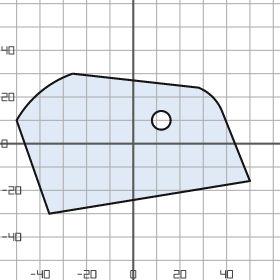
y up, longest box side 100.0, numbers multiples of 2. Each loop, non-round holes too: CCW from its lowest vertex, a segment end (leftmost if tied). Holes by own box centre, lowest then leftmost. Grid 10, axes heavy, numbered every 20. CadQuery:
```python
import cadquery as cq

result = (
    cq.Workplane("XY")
    .moveTo(-36.0, -30.0)
    .lineTo(50.0, -16.0)
    .lineTo(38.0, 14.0)
    .threePointArc((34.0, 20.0), (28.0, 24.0))
    .lineTo(-26.0, 30.0)
    .threePointArc((-40.0, 22.0), (-50.0, 10.0))
    .close()
    .moveTo(12.0, 10.0)
    .circle(4.0)
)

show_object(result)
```